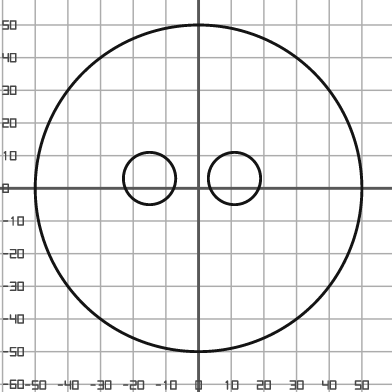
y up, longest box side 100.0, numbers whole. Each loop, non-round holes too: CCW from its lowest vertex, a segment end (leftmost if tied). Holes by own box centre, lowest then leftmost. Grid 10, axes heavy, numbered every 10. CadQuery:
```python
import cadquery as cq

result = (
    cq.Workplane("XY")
    .moveTo(0.0, 0.0)
    .circle(50.0)
    .moveTo(-15.0, 3.0)
    .circle(8.0)
    .moveTo(11.0, 3.0)
    .circle(8.0)
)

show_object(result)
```